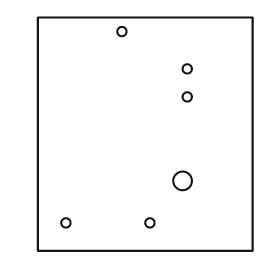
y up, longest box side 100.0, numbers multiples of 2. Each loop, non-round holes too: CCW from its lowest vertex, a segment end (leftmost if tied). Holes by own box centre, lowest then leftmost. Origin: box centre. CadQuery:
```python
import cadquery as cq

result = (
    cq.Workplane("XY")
    .moveTo(-46.0, -50.0)
    .lineTo(46.0, -50.0)
    .lineTo(46.0, 50.0)
    .lineTo(-46.0, 50.0)
    .close()
    .moveTo(-34.0, -38.0)
    .circle(2.0)
    .moveTo(2.0, -38.0)
    .circle(2.0)
    .moveTo(16.0, -20.0)
    .circle(4.0)
    .moveTo(18.0, 16.0)
    .circle(2.0)
    .moveTo(18.0, 28.0)
    .circle(2.0)
    .moveTo(-10.0, 44.0)
    .circle(2.0)
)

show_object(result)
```